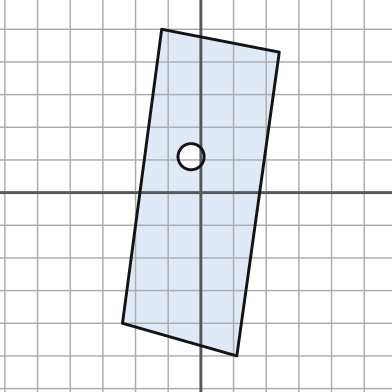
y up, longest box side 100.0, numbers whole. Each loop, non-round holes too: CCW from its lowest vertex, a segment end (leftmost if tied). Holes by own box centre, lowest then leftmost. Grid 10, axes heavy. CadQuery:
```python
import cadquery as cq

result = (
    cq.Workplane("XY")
    .moveTo(11.0, -50.0)
    .lineTo(24.0, 43.0)
    .lineTo(-12.0, 50.0)
    .lineTo(-24.0, -40.0)
    .close()
    .moveTo(-3.0, 11.0)
    .circle(4.0)
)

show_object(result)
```